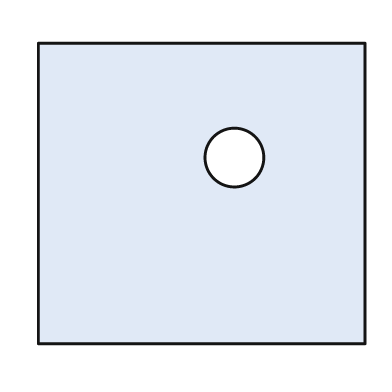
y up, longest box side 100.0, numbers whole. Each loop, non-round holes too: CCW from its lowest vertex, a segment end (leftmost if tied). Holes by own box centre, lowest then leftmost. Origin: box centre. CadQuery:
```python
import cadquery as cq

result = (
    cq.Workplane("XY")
    .moveTo(-50.0, -46.0)
    .lineTo(50.0, -46.0)
    .lineTo(50.0, 46.0)
    .lineTo(-50.0, 46.0)
    .close()
    .moveTo(10.0, 11.0)
    .circle(9.0)
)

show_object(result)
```